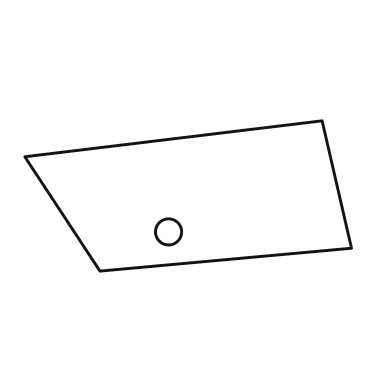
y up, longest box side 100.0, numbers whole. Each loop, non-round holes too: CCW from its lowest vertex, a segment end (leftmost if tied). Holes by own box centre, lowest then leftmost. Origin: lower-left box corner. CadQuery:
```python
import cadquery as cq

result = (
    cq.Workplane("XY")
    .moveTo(23.0, 0.0)
    .lineTo(100.0, 7.0)
    .lineTo(91.0, 46.0)
    .lineTo(0.0, 35.0)
    .close()
    .moveTo(44.0, 12.0)
    .circle(4.0)
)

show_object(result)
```